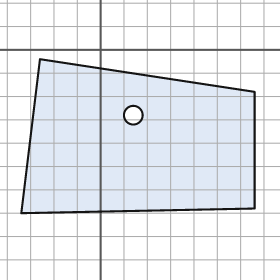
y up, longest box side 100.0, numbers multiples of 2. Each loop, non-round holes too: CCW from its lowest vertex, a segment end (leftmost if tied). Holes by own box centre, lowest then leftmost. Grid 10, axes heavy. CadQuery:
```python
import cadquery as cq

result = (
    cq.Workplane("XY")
    .moveTo(-34.0, -70.0)
    .lineTo(66.0, -68.0)
    .lineTo(66.0, -18.0)
    .lineTo(-26.0, -4.0)
    .close()
    .moveTo(14.0, -28.0)
    .circle(4.0)
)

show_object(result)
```